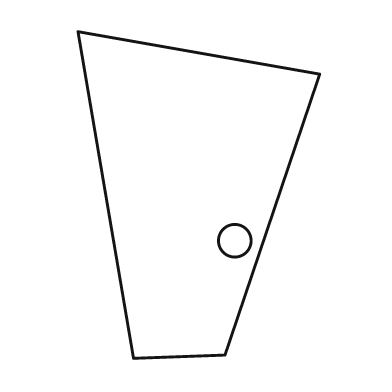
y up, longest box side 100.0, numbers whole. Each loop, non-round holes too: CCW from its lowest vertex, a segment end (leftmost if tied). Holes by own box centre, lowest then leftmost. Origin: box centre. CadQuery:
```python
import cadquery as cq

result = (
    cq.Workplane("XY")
    .moveTo(-20.0, -50.0)
    .lineTo(8.0, -49.0)
    .lineTo(37.0, 37.0)
    .lineTo(-37.0, 50.0)
    .close()
    .moveTo(11.0, -14.0)
    .circle(5.0)
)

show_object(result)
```